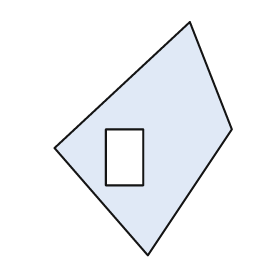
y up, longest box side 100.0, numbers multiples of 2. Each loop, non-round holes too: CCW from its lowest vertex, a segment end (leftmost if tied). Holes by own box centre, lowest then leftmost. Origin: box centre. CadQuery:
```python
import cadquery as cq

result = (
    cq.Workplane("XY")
    .moveTo(2.0, -50.0)
    .lineTo(38.0, 4.0)
    .lineTo(20.0, 50.0)
    .lineTo(-38.0, -4.0)
    .close()
    .moveTo(-16.0, -20.0)
    .lineTo(0.0, -20.0)
    .lineTo(0.0, 4.0)
    .lineTo(-16.0, 4.0)
    .close()
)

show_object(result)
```